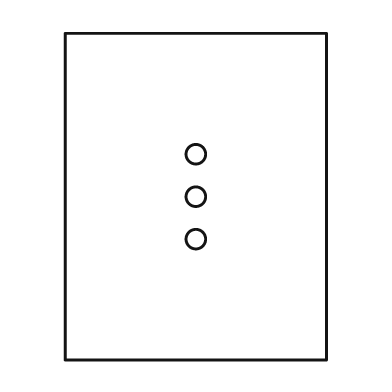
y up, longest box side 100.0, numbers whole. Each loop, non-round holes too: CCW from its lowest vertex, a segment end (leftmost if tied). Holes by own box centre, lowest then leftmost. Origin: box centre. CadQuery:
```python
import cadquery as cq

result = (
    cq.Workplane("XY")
    .moveTo(-40.0, -50.0)
    .lineTo(40.0, -50.0)
    .lineTo(40.0, 50.0)
    .lineTo(-40.0, 50.0)
    .close()
    .moveTo(0.0, -13.0)
    .circle(3.0)
    .moveTo(0.0, 0.0)
    .circle(3.0)
    .moveTo(0.0, 13.0)
    .circle(3.0)
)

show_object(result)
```